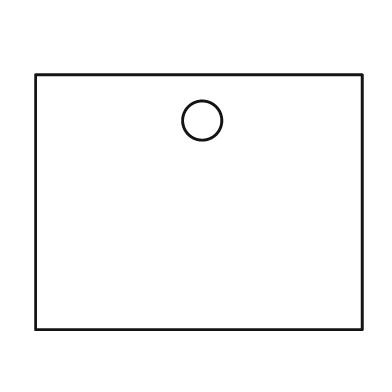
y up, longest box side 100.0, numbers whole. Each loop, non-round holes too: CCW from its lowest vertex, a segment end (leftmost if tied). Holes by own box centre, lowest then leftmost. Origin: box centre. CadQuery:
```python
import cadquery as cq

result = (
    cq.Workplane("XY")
    .moveTo(-50.0, -39.0)
    .lineTo(50.0, -39.0)
    .lineTo(50.0, 39.0)
    .lineTo(-50.0, 39.0)
    .close()
    .moveTo(1.0, 25.0)
    .circle(6.0)
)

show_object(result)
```